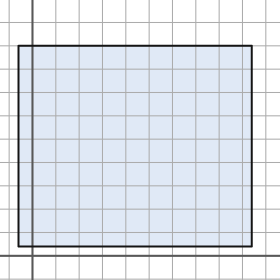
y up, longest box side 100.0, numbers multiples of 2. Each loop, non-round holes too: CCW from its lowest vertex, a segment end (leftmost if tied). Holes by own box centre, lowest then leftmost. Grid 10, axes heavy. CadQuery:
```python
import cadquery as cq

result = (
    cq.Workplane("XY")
    .moveTo(-6.0, 4.0)
    .lineTo(94.0, 4.0)
    .lineTo(94.0, 90.0)
    .lineTo(-6.0, 90.0)
    .close()
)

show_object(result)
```